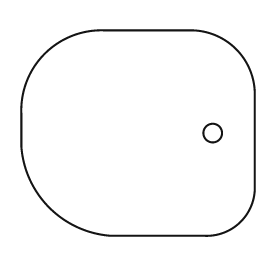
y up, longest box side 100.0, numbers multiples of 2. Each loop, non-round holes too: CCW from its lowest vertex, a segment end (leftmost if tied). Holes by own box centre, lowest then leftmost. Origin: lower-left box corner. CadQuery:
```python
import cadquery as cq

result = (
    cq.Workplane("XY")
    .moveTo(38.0, 0.0)
    .lineTo(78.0, 0.0)
    .threePointArc((94.0, 6.0), (100.0, 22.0))
    .lineTo(100.0, 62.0)
    .threePointArc((92.0, 80.0), (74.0, 88.0))
    .lineTo(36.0, 88.0)
    .threePointArc((10.0, 78.0), (0.0, 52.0))
    .lineTo(0.0, 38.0)
    .threePointArc((12.0, 12.0), (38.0, 0.0))
    .close()
    .moveTo(82.0, 44.0)
    .circle(4.0)
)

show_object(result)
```